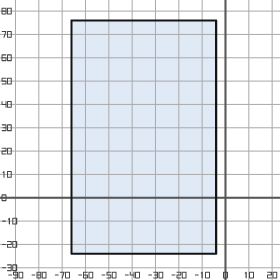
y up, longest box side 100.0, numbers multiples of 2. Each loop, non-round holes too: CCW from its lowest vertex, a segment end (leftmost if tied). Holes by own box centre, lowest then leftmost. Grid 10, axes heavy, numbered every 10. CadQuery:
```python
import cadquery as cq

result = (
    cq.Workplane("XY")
    .moveTo(-66.0, -24.0)
    .lineTo(-4.0, -24.0)
    .lineTo(-4.0, 76.0)
    .lineTo(-66.0, 76.0)
    .close()
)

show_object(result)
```